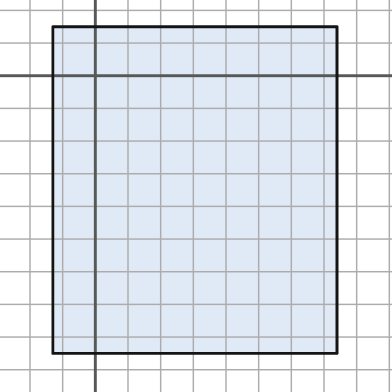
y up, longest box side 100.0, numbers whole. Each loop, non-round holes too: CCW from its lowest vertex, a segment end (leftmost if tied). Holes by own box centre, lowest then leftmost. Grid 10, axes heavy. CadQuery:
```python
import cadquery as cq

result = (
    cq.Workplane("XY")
    .moveTo(-13.0, -85.0)
    .lineTo(74.0, -85.0)
    .lineTo(74.0, 15.0)
    .lineTo(-13.0, 15.0)
    .close()
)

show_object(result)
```